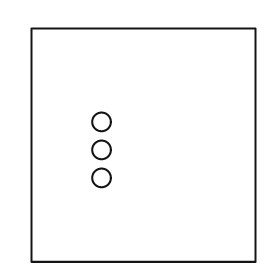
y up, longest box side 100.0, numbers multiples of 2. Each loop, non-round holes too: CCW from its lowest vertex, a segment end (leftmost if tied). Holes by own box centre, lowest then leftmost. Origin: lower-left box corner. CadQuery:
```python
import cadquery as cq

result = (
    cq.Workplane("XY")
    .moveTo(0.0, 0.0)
    .lineTo(96.0, 0.0)
    .lineTo(96.0, 100.0)
    .lineTo(0.0, 100.0)
    .close()
    .moveTo(30.0, 36.0)
    .circle(4.0)
    .moveTo(30.0, 48.0)
    .circle(4.0)
    .moveTo(30.0, 60.0)
    .circle(4.0)
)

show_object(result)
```